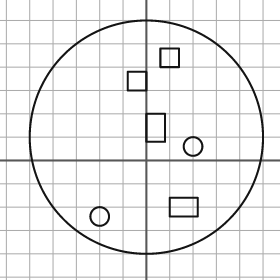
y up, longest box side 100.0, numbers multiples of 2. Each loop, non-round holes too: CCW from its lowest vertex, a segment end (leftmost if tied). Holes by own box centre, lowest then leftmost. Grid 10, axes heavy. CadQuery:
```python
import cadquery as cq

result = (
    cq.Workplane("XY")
    .moveTo(0.0, 10.0)
    .circle(50.0)
    .moveTo(-20.0, -24.0)
    .circle(4.0)
    .moveTo(10.0, -24.0)
    .lineTo(22.0, -24.0)
    .lineTo(22.0, -16.0)
    .lineTo(10.0, -16.0)
    .close()
    .moveTo(20.0, 6.0)
    .circle(4.0)
    .moveTo(0.0, 8.0)
    .lineTo(8.0, 8.0)
    .lineTo(8.0, 20.0)
    .lineTo(0.0, 20.0)
    .close()
    .moveTo(-8.0, 30.0)
    .lineTo(0.0, 30.0)
    .lineTo(0.0, 38.0)
    .lineTo(-8.0, 38.0)
    .close()
    .moveTo(6.0, 40.0)
    .lineTo(14.0, 40.0)
    .lineTo(14.0, 48.0)
    .lineTo(6.0, 48.0)
    .close()
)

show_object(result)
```